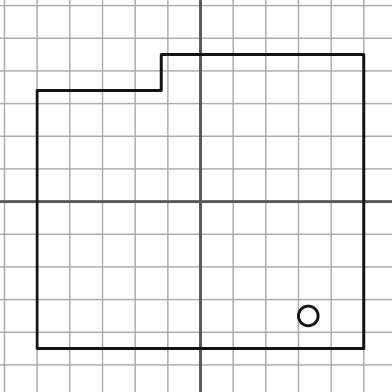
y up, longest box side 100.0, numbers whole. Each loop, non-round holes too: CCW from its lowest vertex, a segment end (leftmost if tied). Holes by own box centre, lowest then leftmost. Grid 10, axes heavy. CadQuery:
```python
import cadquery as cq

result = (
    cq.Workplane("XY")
    .moveTo(-50.0, -45.0)
    .lineTo(50.0, -45.0)
    .lineTo(50.0, 45.0)
    .lineTo(-12.0, 45.0)
    .lineTo(-12.0, 34.0)
    .lineTo(-50.0, 34.0)
    .close()
    .moveTo(33.0, -35.0)
    .circle(3.0)
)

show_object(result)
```